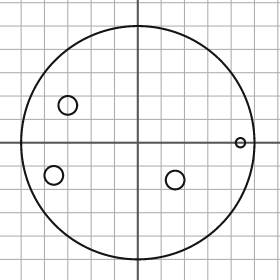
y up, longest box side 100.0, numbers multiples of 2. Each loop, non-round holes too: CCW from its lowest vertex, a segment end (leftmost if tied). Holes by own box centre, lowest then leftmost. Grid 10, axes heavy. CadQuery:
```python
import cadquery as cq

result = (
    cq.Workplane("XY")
    .moveTo(0.0, 0.0)
    .circle(50.0)
    .moveTo(16.0, -16.0)
    .circle(4.0)
    .moveTo(-36.0, -14.0)
    .circle(4.0)
    .moveTo(44.0, 0.0)
    .circle(2.0)
    .moveTo(-30.0, 16.0)
    .circle(4.0)
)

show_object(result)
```